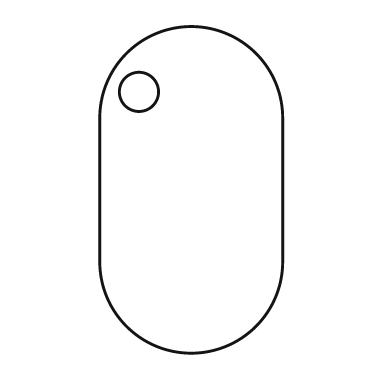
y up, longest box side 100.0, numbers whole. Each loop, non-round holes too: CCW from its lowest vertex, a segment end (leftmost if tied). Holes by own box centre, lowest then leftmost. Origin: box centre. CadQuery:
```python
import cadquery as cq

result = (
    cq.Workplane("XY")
    .moveTo(-28.0, -22.0)
    .threePointArc((0.0, -50.0), (28.0, -22.0))
    .lineTo(28.0, 22.0)
    .threePointArc((0.0, 50.0), (-28.0, 22.0))
    .close()
    .moveTo(-16.0, 30.0)
    .circle(6.0)
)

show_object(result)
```